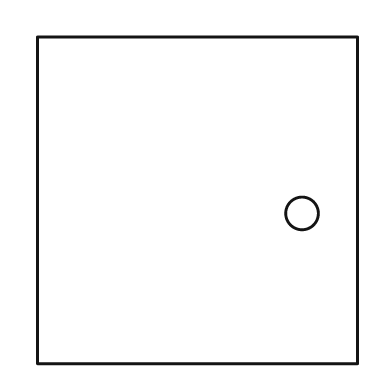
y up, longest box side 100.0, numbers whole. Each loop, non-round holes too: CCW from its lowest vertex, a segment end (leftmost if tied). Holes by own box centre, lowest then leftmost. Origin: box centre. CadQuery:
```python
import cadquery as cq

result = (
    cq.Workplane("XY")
    .moveTo(-49.0, -50.0)
    .lineTo(49.0, -50.0)
    .lineTo(49.0, 50.0)
    .lineTo(-49.0, 50.0)
    .close()
    .moveTo(32.0, -4.0)
    .circle(5.0)
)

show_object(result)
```